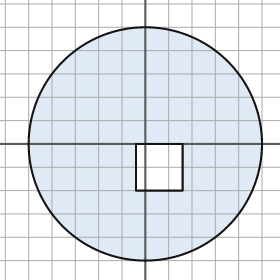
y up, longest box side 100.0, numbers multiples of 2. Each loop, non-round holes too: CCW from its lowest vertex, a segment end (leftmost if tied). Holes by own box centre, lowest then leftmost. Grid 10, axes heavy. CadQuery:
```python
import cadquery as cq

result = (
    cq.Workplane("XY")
    .moveTo(0.0, 0.0)
    .circle(50.0)
    .moveTo(-4.0, -20.0)
    .lineTo(16.0, -20.0)
    .lineTo(16.0, 0.0)
    .lineTo(-4.0, 0.0)
    .close()
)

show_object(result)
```